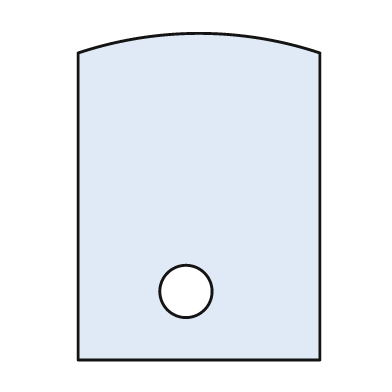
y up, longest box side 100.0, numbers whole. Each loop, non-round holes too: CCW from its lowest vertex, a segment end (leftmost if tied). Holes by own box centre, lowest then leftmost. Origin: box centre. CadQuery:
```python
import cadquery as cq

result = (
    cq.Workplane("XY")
    .moveTo(-37.0, -50.0)
    .lineTo(37.0, -50.0)
    .lineTo(37.0, 44.0)
    .threePointArc((0.0, 50.0), (-37.0, 44.0))
    .close()
    .moveTo(-4.0, -29.0)
    .circle(8.0)
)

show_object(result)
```